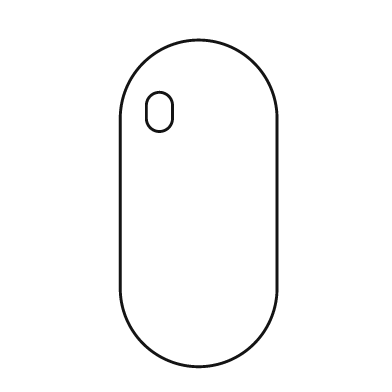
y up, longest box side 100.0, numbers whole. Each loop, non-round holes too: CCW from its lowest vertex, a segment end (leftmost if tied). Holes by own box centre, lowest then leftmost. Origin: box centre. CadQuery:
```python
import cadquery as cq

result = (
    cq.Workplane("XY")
    .moveTo(-24.0, -26.0)
    .threePointArc((0.0, -50.0), (24.0, -26.0))
    .lineTo(24.0, 26.0)
    .threePointArc((0.0, 50.0), (-24.0, 26.0))
    .close()
    .moveTo(-16.0, 26.0)
    .threePointArc((-12.0, 22.0), (-8.0, 26.0))
    .lineTo(-8.0, 30.0)
    .threePointArc((-12.0, 34.0), (-16.0, 30.0))
    .close()
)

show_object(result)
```